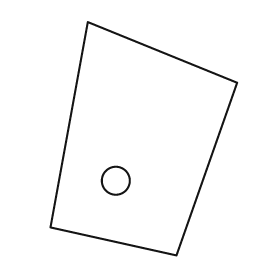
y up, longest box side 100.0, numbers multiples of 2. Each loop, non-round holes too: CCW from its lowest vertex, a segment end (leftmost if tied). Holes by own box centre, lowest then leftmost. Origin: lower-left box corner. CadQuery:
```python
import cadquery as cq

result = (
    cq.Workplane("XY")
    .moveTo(54.0, 0.0)
    .lineTo(80.0, 74.0)
    .lineTo(16.0, 100.0)
    .lineTo(0.0, 12.0)
    .close()
    .moveTo(28.0, 32.0)
    .circle(6.0)
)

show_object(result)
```